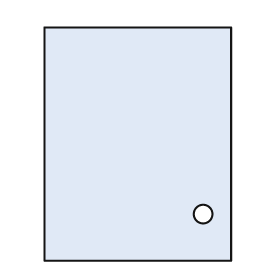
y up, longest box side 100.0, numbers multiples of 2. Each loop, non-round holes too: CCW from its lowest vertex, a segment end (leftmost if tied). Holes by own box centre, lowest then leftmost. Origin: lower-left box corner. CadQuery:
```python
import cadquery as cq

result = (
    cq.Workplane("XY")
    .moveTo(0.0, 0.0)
    .lineTo(80.0, 0.0)
    .lineTo(80.0, 100.0)
    .lineTo(0.0, 100.0)
    .close()
    .moveTo(68.0, 20.0)
    .circle(4.0)
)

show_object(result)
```